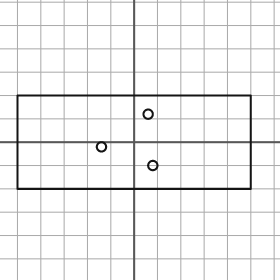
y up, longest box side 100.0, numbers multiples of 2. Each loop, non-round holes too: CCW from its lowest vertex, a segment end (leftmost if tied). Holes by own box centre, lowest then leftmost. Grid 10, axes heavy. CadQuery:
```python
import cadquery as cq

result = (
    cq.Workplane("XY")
    .moveTo(-50.0, -20.0)
    .lineTo(50.0, -20.0)
    .lineTo(50.0, 20.0)
    .lineTo(-50.0, 20.0)
    .close()
    .moveTo(8.0, -10.0)
    .circle(2.0)
    .moveTo(-14.0, -2.0)
    .circle(2.0)
    .moveTo(6.0, 12.0)
    .circle(2.0)
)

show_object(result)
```